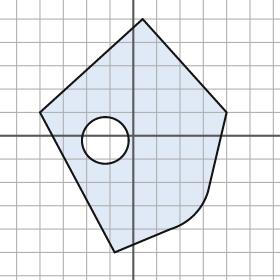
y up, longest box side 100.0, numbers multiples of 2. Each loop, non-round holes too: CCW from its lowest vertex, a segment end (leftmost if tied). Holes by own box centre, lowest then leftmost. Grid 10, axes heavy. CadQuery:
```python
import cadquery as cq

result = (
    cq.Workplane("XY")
    .moveTo(-8.0, -50.0)
    .lineTo(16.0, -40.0)
    .threePointArc((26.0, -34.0), (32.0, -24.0))
    .lineTo(40.0, 10.0)
    .lineTo(4.0, 50.0)
    .lineTo(-40.0, 10.0)
    .close()
    .moveTo(-12.0, -2.0)
    .circle(10.0)
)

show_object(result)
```